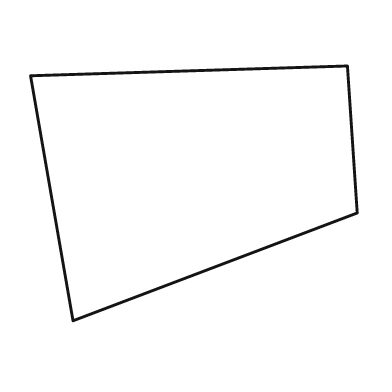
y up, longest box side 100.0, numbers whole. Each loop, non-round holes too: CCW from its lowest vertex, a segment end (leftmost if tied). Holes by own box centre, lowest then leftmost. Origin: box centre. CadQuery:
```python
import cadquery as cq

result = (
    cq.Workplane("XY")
    .moveTo(-37.0, -39.0)
    .lineTo(50.0, -6.0)
    .lineTo(47.0, 39.0)
    .lineTo(-50.0, 36.0)
    .close()
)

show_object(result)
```